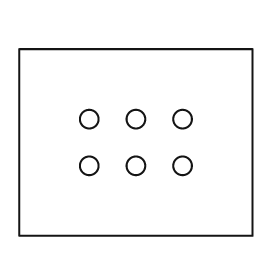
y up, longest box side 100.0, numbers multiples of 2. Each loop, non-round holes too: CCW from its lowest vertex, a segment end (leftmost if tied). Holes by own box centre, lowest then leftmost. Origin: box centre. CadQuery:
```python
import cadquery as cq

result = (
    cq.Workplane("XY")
    .moveTo(-50.0, -40.0)
    .lineTo(50.0, -40.0)
    .lineTo(50.0, 40.0)
    .lineTo(-50.0, 40.0)
    .close()
    .moveTo(-20.0, -10.0)
    .circle(4.0)
    .moveTo(0.0, -10.0)
    .circle(4.0)
    .moveTo(20.0, -10.0)
    .circle(4.0)
    .moveTo(-20.0, 10.0)
    .circle(4.0)
    .moveTo(0.0, 10.0)
    .circle(4.0)
    .moveTo(20.0, 10.0)
    .circle(4.0)
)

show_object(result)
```